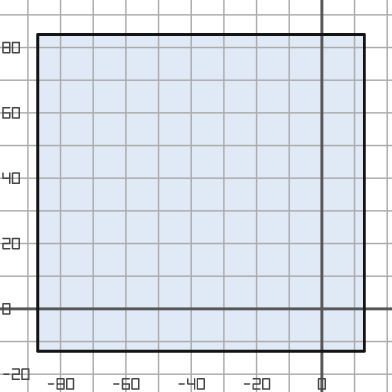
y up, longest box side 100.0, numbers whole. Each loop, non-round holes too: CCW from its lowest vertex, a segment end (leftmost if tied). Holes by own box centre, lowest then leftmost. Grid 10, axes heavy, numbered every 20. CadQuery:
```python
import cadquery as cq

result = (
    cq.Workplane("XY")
    .moveTo(-87.0, -13.0)
    .lineTo(13.0, -13.0)
    .lineTo(13.0, 84.0)
    .lineTo(-87.0, 84.0)
    .close()
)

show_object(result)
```